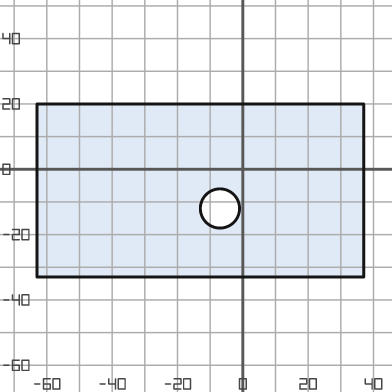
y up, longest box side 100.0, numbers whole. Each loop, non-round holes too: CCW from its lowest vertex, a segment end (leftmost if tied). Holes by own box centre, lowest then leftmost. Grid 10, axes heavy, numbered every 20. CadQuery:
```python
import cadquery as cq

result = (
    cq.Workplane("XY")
    .moveTo(-63.0, -33.0)
    .lineTo(37.0, -33.0)
    .lineTo(37.0, 20.0)
    .lineTo(-63.0, 20.0)
    .close()
    .moveTo(-7.0, -12.0)
    .circle(6.0)
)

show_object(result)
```